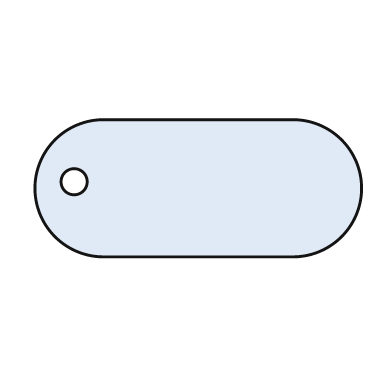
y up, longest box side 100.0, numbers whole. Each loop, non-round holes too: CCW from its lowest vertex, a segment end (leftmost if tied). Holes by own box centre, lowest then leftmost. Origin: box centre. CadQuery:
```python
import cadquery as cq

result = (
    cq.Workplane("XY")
    .moveTo(-29.0, -21.0)
    .lineTo(29.0, -21.0)
    .threePointArc((50.0, 0.0), (29.0, 21.0))
    .lineTo(-29.0, 21.0)
    .threePointArc((-50.0, 0.0), (-29.0, -21.0))
    .close()
    .moveTo(-38.0, 2.0)
    .circle(4.0)
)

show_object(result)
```